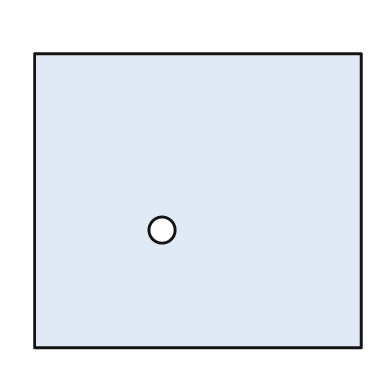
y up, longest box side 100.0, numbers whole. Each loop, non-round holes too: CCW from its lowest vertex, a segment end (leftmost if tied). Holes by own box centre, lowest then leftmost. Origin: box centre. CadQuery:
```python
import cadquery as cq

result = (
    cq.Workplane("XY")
    .moveTo(-50.0, -45.0)
    .lineTo(50.0, -45.0)
    .lineTo(50.0, 45.0)
    .lineTo(-50.0, 45.0)
    .close()
    .moveTo(-11.0, -9.0)
    .circle(4.0)
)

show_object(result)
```